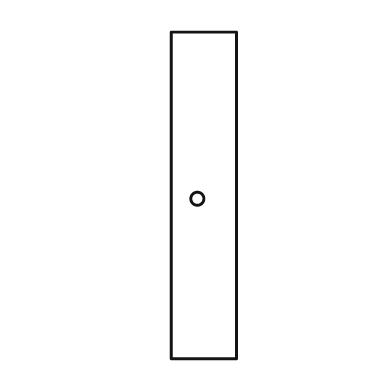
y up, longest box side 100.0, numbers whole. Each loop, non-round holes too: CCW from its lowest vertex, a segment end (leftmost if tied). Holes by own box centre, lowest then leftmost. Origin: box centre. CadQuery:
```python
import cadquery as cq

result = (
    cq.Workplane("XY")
    .moveTo(-10.0, -50.0)
    .lineTo(10.0, -50.0)
    .lineTo(10.0, 50.0)
    .lineTo(-10.0, 50.0)
    .close()
    .moveTo(-2.0, -1.0)
    .circle(2.0)
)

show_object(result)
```